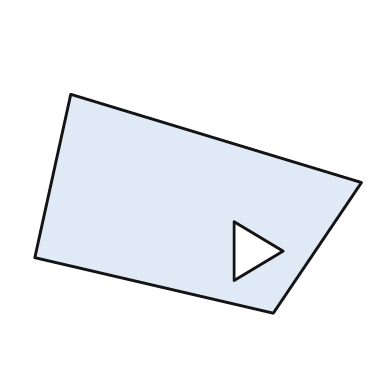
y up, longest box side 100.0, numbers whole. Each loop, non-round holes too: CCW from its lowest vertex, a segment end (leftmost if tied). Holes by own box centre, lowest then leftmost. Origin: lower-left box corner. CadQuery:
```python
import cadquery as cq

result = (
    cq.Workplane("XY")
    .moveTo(73.0, 0.0)
    .lineTo(100.0, 40.0)
    .lineTo(11.0, 67.0)
    .lineTo(0.0, 17.0)
    .close()
    .moveTo(61.0, 10.0)
    .lineTo(76.0, 19.0)
    .lineTo(61.0, 28.0)
    .close()
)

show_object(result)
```